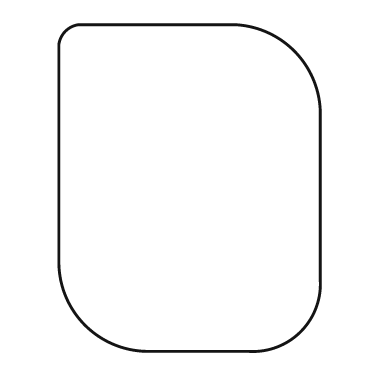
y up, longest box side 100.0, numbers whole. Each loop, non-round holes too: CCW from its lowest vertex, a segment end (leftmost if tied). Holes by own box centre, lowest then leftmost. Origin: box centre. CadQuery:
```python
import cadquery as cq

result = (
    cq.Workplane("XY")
    .moveTo(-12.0, -50.0)
    .lineTo(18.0, -50.0)
    .threePointArc((34.0, -44.0), (40.0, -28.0))
    .lineTo(40.0, 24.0)
    .threePointArc((32.0, 42.0), (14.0, 50.0))
    .lineTo(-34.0, 50.0)
    .threePointArc((-38.0, 48.0), (-40.0, 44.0))
    .lineTo(-40.0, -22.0)
    .threePointArc((-32.0, -42.0), (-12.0, -50.0))
    .close()
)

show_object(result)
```